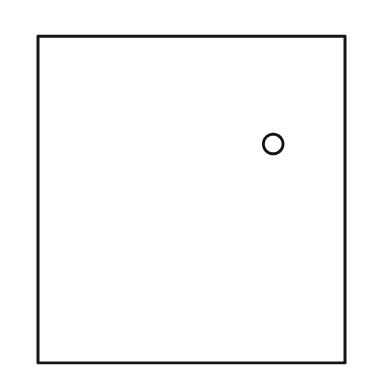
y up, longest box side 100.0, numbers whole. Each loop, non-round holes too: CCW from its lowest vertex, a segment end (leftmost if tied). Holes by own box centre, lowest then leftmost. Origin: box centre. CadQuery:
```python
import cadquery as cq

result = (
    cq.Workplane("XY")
    .moveTo(-47.0, -50.0)
    .lineTo(47.0, -50.0)
    .lineTo(47.0, 50.0)
    .lineTo(-47.0, 50.0)
    .close()
    .moveTo(25.0, 17.0)
    .circle(3.0)
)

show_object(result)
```